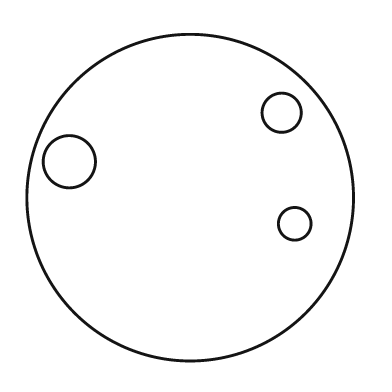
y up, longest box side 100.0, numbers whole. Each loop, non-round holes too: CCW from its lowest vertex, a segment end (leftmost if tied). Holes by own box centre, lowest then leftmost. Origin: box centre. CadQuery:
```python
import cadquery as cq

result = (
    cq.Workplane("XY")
    .moveTo(0.0, 0.0)
    .circle(50.0)
    .moveTo(32.0, -8.0)
    .circle(5.0)
    .moveTo(-37.0, 11.0)
    .circle(8.0)
    .moveTo(28.0, 26.0)
    .circle(6.0)
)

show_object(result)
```